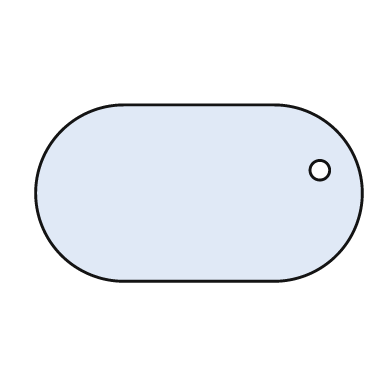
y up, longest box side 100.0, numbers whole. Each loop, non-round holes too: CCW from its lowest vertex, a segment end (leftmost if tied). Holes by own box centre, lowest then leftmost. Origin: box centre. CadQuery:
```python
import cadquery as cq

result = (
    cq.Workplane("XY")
    .moveTo(-23.0, -27.0)
    .lineTo(23.0, -27.0)
    .threePointArc((50.0, 0.0), (23.0, 27.0))
    .lineTo(-23.0, 27.0)
    .threePointArc((-50.0, 0.0), (-23.0, -27.0))
    .close()
    .moveTo(37.0, 7.0)
    .circle(3.0)
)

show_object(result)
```